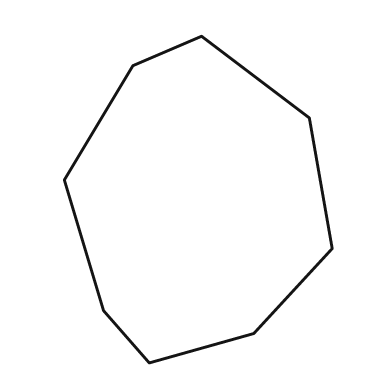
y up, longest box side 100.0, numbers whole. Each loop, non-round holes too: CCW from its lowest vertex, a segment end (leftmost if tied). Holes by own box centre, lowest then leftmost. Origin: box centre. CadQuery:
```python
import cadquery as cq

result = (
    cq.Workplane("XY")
    .moveTo(-15.0, -50.0)
    .lineTo(17.0, -41.0)
    .lineTo(41.0, -15.0)
    .lineTo(34.0, 25.0)
    .lineTo(1.0, 50.0)
    .lineTo(-20.0, 41.0)
    .lineTo(-41.0, 6.0)
    .lineTo(-29.0, -34.0)
    .close()
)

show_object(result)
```